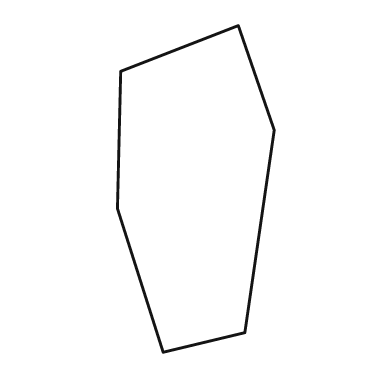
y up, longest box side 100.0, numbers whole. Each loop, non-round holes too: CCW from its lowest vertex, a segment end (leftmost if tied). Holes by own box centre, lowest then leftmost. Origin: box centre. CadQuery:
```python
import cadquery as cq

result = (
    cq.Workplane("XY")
    .moveTo(-10.0, -50.0)
    .lineTo(15.0, -44.0)
    .lineTo(24.0, 18.0)
    .lineTo(13.0, 50.0)
    .lineTo(-23.0, 36.0)
    .lineTo(-24.0, -6.0)
    .close()
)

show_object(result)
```